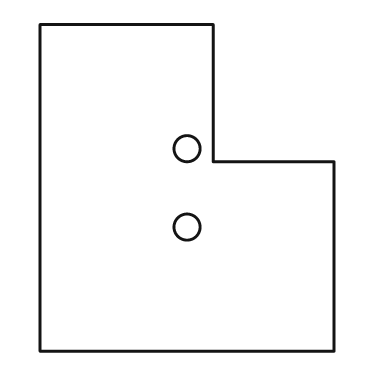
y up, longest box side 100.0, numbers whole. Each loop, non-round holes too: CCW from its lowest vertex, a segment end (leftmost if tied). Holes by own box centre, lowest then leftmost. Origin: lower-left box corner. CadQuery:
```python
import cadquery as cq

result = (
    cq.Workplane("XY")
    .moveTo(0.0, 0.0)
    .lineTo(90.0, 0.0)
    .lineTo(90.0, 58.0)
    .lineTo(53.0, 58.0)
    .lineTo(53.0, 100.0)
    .lineTo(0.0, 100.0)
    .close()
    .moveTo(45.0, 38.0)
    .circle(4.0)
    .moveTo(45.0, 62.0)
    .circle(4.0)
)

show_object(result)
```